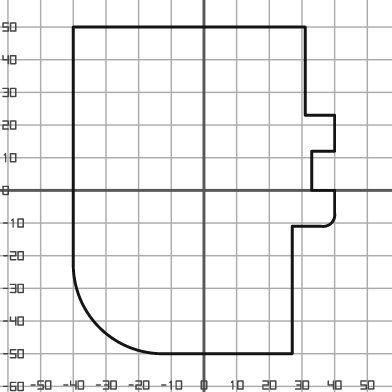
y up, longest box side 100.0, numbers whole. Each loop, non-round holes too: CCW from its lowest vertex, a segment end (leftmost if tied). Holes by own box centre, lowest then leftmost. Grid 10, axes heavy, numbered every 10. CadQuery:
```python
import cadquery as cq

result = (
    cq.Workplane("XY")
    .moveTo(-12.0, -50.0)
    .lineTo(27.0, -50.0)
    .lineTo(27.0, -11.0)
    .lineTo(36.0, -11.0)
    .threePointArc((39.0, -10.0), (40.0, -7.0))
    .lineTo(40.0, 0.0)
    .lineTo(33.0, 0.0)
    .lineTo(33.0, 12.0)
    .lineTo(40.0, 12.0)
    .lineTo(40.0, 23.0)
    .lineTo(31.0, 23.0)
    .lineTo(31.0, 50.0)
    .lineTo(-40.0, 50.0)
    .lineTo(-40.0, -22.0)
    .threePointArc((-32.0, -42.0), (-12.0, -50.0))
    .close()
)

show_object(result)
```